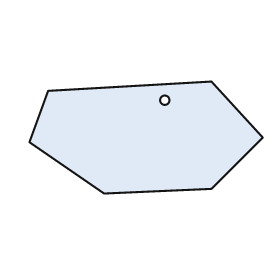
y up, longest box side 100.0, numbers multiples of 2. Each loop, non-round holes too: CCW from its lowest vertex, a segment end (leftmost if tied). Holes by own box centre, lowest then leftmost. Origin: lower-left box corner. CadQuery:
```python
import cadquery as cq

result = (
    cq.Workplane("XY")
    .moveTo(32.0, 0.0)
    .lineTo(78.0, 2.0)
    .lineTo(100.0, 24.0)
    .lineTo(78.0, 48.0)
    .lineTo(8.0, 44.0)
    .lineTo(0.0, 22.0)
    .close()
    .moveTo(58.0, 40.0)
    .circle(2.0)
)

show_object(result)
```